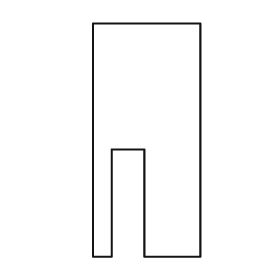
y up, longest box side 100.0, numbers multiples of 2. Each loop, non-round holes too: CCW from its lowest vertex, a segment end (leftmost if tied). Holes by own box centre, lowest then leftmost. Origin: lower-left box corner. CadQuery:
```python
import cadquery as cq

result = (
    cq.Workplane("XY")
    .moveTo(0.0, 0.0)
    .lineTo(8.0, 0.0)
    .lineTo(8.0, 46.0)
    .lineTo(22.0, 46.0)
    .lineTo(22.0, 0.0)
    .lineTo(46.0, 0.0)
    .lineTo(46.0, 100.0)
    .lineTo(0.0, 100.0)
    .close()
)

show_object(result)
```